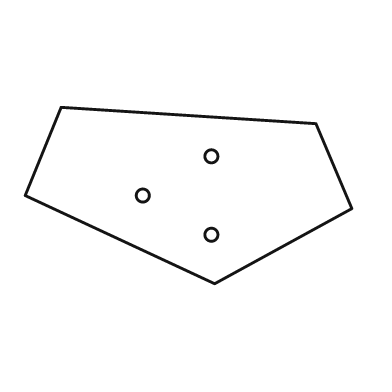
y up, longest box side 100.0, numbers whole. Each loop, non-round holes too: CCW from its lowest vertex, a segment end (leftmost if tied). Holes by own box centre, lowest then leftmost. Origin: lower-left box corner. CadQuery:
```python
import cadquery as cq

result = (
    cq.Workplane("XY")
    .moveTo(58.0, 0.0)
    .lineTo(100.0, 23.0)
    .lineTo(89.0, 49.0)
    .lineTo(11.0, 54.0)
    .lineTo(0.0, 27.0)
    .close()
    .moveTo(57.0, 15.0)
    .circle(2.0)
    .moveTo(36.0, 27.0)
    .circle(2.0)
    .moveTo(57.0, 39.0)
    .circle(2.0)
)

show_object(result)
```